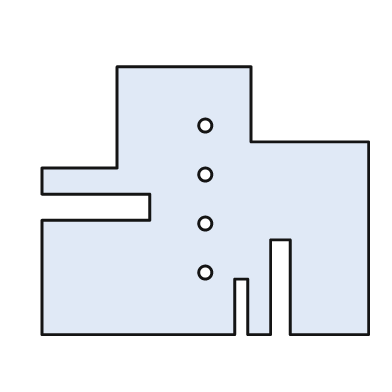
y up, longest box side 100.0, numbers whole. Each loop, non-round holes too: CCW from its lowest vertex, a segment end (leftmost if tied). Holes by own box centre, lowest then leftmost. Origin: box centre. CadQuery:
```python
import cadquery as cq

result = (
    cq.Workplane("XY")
    .moveTo(-50.0, -41.0)
    .lineTo(9.0, -41.0)
    .lineTo(9.0, -24.0)
    .lineTo(13.0, -24.0)
    .lineTo(13.0, -41.0)
    .lineTo(20.0, -41.0)
    .lineTo(20.0, -12.0)
    .lineTo(26.0, -12.0)
    .lineTo(26.0, -41.0)
    .lineTo(50.0, -41.0)
    .lineTo(50.0, 18.0)
    .lineTo(14.0, 18.0)
    .lineTo(14.0, 41.0)
    .lineTo(-27.0, 41.0)
    .lineTo(-27.0, 10.0)
    .lineTo(-50.0, 10.0)
    .lineTo(-50.0, 2.0)
    .lineTo(-17.0, 2.0)
    .lineTo(-17.0, -6.0)
    .lineTo(-50.0, -6.0)
    .close()
    .moveTo(0.0, -22.0)
    .circle(2.0)
    .moveTo(0.0, -7.0)
    .circle(2.0)
    .moveTo(0.0, 8.0)
    .circle(2.0)
    .moveTo(0.0, 23.0)
    .circle(2.0)
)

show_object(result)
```